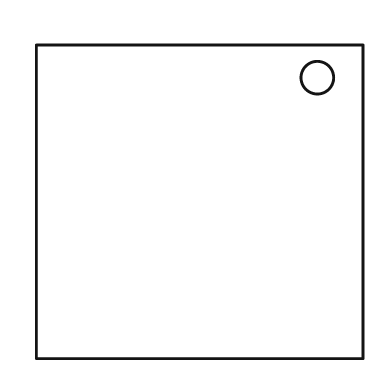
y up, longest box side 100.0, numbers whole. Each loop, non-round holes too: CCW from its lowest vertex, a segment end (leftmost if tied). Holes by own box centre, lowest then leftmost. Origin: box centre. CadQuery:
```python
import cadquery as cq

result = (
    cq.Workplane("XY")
    .moveTo(-50.0, -48.0)
    .lineTo(50.0, -48.0)
    .lineTo(50.0, 48.0)
    .lineTo(-50.0, 48.0)
    .close()
    .moveTo(36.0, 38.0)
    .circle(5.0)
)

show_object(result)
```